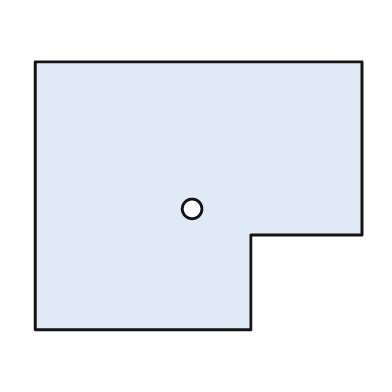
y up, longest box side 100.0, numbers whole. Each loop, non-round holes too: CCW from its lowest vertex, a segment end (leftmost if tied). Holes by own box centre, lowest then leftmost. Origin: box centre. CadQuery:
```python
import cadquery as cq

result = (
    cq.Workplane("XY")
    .moveTo(-50.0, -41.0)
    .lineTo(16.0, -41.0)
    .lineTo(16.0, -12.0)
    .lineTo(50.0, -12.0)
    .lineTo(50.0, 41.0)
    .lineTo(-50.0, 41.0)
    .close()
    .moveTo(-2.0, -4.0)
    .circle(3.0)
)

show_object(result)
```